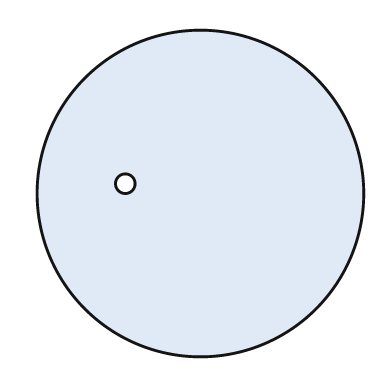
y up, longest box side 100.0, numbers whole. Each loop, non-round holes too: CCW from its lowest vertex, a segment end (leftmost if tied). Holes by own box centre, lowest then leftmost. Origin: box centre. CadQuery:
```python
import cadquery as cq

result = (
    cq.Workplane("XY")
    .moveTo(0.0, 0.0)
    .circle(50.0)
    .moveTo(-23.0, 3.0)
    .circle(3.0)
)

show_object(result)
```